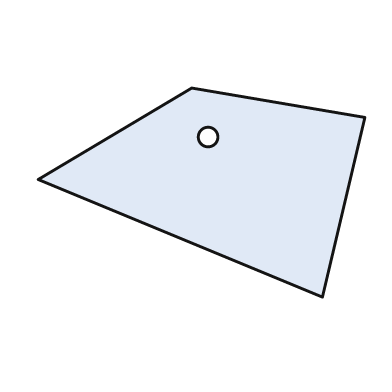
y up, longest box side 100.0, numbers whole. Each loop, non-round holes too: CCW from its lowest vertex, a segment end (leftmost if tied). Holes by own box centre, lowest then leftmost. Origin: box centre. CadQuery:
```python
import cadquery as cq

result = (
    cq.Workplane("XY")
    .moveTo(37.0, -32.0)
    .lineTo(50.0, 23.0)
    .lineTo(-3.0, 32.0)
    .lineTo(-50.0, 4.0)
    .close()
    .moveTo(2.0, 17.0)
    .circle(3.0)
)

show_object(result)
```